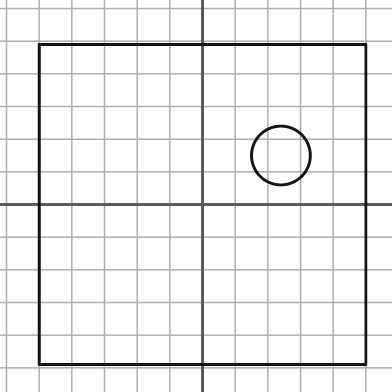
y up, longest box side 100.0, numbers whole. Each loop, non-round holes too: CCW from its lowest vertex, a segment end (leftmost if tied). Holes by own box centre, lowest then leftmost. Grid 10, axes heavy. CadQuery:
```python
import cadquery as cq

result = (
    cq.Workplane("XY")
    .moveTo(-50.0, -49.0)
    .lineTo(50.0, -49.0)
    .lineTo(50.0, 49.0)
    .lineTo(-50.0, 49.0)
    .close()
    .moveTo(24.0, 15.0)
    .circle(9.0)
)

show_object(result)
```